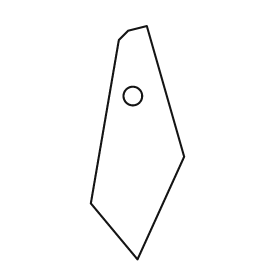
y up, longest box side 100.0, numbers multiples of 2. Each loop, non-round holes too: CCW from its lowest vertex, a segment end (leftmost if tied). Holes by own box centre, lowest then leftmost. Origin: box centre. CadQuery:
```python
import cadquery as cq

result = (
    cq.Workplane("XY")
    .moveTo(0.0, -50.0)
    .lineTo(20.0, -6.0)
    .lineTo(4.0, 50.0)
    .lineTo(-4.0, 48.0)
    .lineTo(-8.0, 44.0)
    .lineTo(-20.0, -26.0)
    .close()
    .moveTo(-2.0, 20.0)
    .circle(4.0)
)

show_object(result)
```